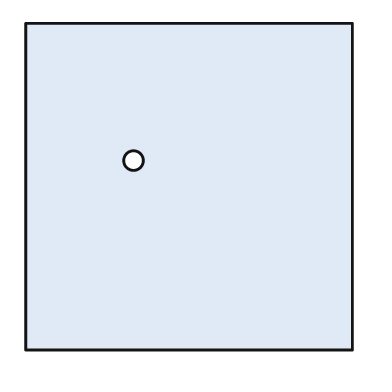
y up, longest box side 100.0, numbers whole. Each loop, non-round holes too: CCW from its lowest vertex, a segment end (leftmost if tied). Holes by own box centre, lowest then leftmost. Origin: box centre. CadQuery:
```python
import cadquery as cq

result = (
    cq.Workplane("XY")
    .moveTo(-50.0, -50.0)
    .lineTo(50.0, -50.0)
    .lineTo(50.0, 50.0)
    .lineTo(-50.0, 50.0)
    .close()
    .moveTo(-17.0, 8.0)
    .circle(3.0)
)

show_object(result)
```